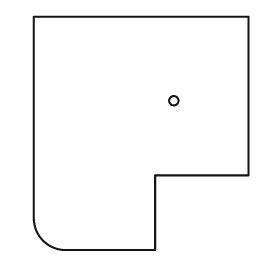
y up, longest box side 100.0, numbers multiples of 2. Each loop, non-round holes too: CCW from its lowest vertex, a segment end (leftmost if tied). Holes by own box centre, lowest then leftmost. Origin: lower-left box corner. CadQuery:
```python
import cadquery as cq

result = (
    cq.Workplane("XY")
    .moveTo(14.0, 0.0)
    .lineTo(52.0, 0.0)
    .lineTo(52.0, 32.0)
    .lineTo(92.0, 32.0)
    .lineTo(92.0, 100.0)
    .lineTo(0.0, 100.0)
    .lineTo(0.0, 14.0)
    .threePointArc((4.0, 4.0), (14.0, 0.0))
    .close()
    .moveTo(60.0, 64.0)
    .circle(2.0)
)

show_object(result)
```